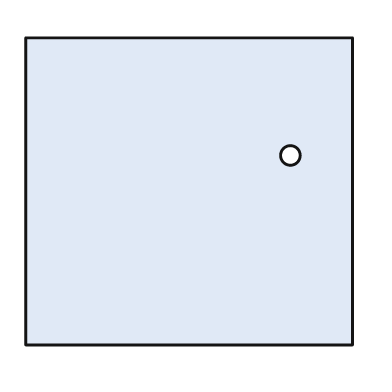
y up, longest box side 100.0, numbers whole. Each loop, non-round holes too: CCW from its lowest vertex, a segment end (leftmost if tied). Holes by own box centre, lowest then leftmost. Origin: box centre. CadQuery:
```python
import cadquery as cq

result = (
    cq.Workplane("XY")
    .moveTo(-50.0, -47.0)
    .lineTo(50.0, -47.0)
    .lineTo(50.0, 47.0)
    .lineTo(-50.0, 47.0)
    .close()
    .moveTo(31.0, 11.0)
    .circle(3.0)
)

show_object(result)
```